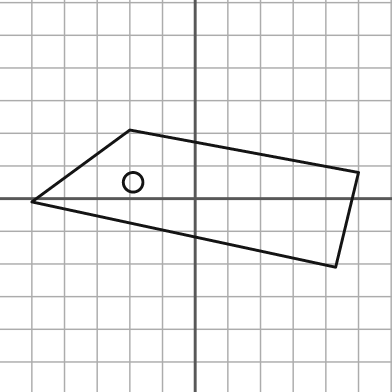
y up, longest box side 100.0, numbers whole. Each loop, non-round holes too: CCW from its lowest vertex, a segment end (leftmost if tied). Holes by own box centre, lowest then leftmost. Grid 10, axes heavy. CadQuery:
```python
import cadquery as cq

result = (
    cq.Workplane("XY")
    .moveTo(43.0, -21.0)
    .lineTo(50.0, 8.0)
    .lineTo(-20.0, 21.0)
    .lineTo(-50.0, -1.0)
    .close()
    .moveTo(-19.0, 5.0)
    .circle(3.0)
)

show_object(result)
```